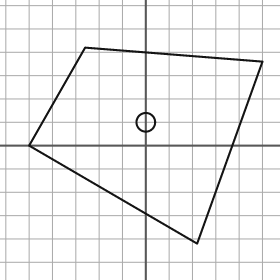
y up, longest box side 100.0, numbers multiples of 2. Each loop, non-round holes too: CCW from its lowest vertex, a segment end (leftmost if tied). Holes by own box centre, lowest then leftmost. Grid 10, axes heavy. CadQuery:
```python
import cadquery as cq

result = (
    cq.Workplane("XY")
    .moveTo(22.0, -42.0)
    .lineTo(50.0, 36.0)
    .lineTo(-26.0, 42.0)
    .lineTo(-50.0, 0.0)
    .close()
    .moveTo(0.0, 10.0)
    .circle(4.0)
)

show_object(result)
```